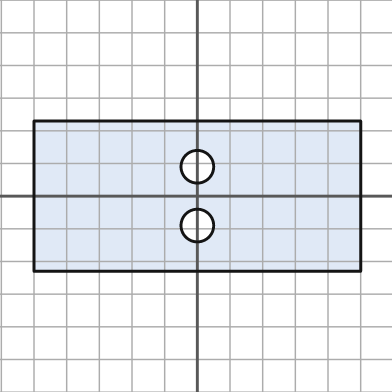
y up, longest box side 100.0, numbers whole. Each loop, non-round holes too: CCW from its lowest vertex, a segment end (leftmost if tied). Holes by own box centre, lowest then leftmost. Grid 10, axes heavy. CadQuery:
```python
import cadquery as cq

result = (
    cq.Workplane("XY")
    .moveTo(-50.0, -23.0)
    .lineTo(50.0, -23.0)
    .lineTo(50.0, 23.0)
    .lineTo(-50.0, 23.0)
    .close()
    .moveTo(0.0, -9.0)
    .circle(5.0)
    .moveTo(0.0, 9.0)
    .circle(5.0)
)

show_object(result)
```